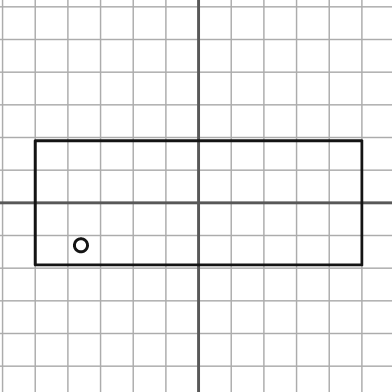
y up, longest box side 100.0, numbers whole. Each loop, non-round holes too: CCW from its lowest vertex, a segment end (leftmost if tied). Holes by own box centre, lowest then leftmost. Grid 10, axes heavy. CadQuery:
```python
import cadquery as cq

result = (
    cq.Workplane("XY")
    .moveTo(-50.0, -19.0)
    .lineTo(50.0, -19.0)
    .lineTo(50.0, 19.0)
    .lineTo(-50.0, 19.0)
    .close()
    .moveTo(-36.0, -13.0)
    .circle(2.0)
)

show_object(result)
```